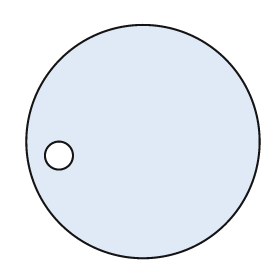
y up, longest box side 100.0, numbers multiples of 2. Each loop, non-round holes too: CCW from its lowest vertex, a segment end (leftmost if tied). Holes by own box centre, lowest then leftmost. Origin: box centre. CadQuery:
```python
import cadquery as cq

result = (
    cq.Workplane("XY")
    .moveTo(0.0, 0.0)
    .circle(50.0)
    .moveTo(-36.0, -6.0)
    .circle(6.0)
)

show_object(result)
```